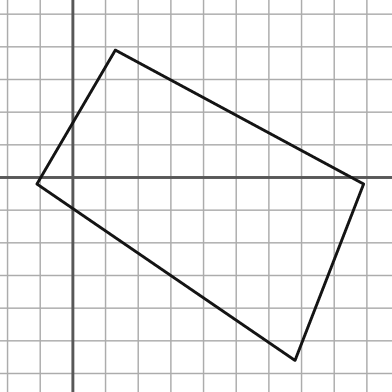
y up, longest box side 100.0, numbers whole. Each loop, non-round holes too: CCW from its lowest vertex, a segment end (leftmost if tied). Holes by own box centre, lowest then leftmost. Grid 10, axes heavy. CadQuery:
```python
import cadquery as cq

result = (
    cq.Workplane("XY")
    .moveTo(68.0, -56.0)
    .lineTo(89.0, -2.0)
    .lineTo(13.0, 39.0)
    .lineTo(-11.0, -2.0)
    .close()
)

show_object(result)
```